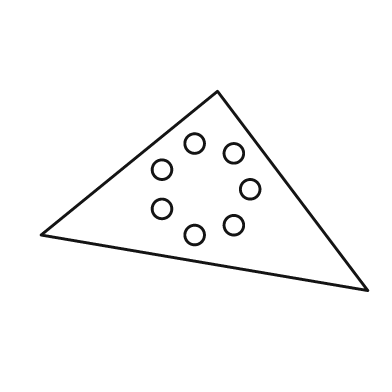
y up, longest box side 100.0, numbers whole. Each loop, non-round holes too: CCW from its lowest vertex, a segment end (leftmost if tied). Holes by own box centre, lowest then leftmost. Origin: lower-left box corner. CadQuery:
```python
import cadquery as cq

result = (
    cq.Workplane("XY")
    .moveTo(100.0, 0.0)
    .lineTo(54.0, 61.0)
    .lineTo(0.0, 17.0)
    .close()
    .moveTo(47.0, 17.0)
    .circle(3.0)
    .moveTo(59.0, 20.0)
    .circle(3.0)
    .moveTo(37.0, 25.0)
    .circle(3.0)
    .moveTo(64.0, 31.0)
    .circle(3.0)
    .moveTo(37.0, 37.0)
    .circle(3.0)
    .moveTo(59.0, 42.0)
    .circle(3.0)
    .moveTo(47.0, 45.0)
    .circle(3.0)
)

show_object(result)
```